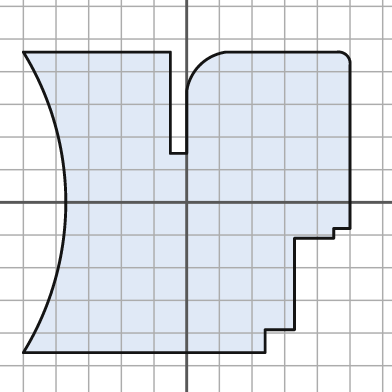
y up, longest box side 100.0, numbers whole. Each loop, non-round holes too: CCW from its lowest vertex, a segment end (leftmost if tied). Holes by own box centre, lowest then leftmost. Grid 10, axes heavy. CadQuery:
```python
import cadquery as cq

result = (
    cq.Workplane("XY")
    .moveTo(-50.0, -46.0)
    .lineTo(24.0, -46.0)
    .lineTo(24.0, -39.0)
    .lineTo(33.0, -39.0)
    .lineTo(33.0, -11.0)
    .lineTo(45.0, -11.0)
    .lineTo(45.0, -8.0)
    .lineTo(50.0, -8.0)
    .lineTo(50.0, 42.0)
    .threePointArc((49.0, 45.0), (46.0, 46.0))
    .lineTo(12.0, 46.0)
    .threePointArc((4.0, 42.0), (0.0, 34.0))
    .lineTo(0.0, 15.0)
    .lineTo(-5.0, 15.0)
    .lineTo(-5.0, 46.0)
    .lineTo(-50.0, 46.0)
    .threePointArc((-37.0, 0.0), (-50.0, -46.0))
    .close()
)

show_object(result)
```